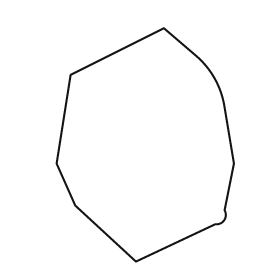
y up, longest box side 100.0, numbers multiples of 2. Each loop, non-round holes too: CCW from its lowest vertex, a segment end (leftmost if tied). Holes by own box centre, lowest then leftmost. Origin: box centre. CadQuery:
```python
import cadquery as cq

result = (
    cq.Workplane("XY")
    .moveTo(-4.0, -50.0)
    .lineTo(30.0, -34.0)
    .threePointArc((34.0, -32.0), (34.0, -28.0))
    .lineTo(38.0, -8.0)
    .lineTo(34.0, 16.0)
    .threePointArc((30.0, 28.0), (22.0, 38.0))
    .lineTo(8.0, 50.0)
    .lineTo(-32.0, 30.0)
    .lineTo(-38.0, -8.0)
    .lineTo(-30.0, -26.0)
    .close()
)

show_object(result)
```